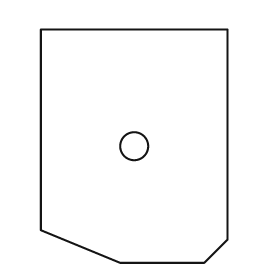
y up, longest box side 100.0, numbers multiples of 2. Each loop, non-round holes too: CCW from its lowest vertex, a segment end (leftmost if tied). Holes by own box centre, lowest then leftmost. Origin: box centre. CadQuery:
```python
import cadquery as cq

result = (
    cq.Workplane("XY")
    .moveTo(-6.0, -50.0)
    .lineTo(30.0, -50.0)
    .lineTo(40.0, -40.0)
    .lineTo(40.0, 50.0)
    .lineTo(-40.0, 50.0)
    .lineTo(-40.0, -36.0)
    .close()
    .moveTo(0.0, 0.0)
    .circle(6.0)
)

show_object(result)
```